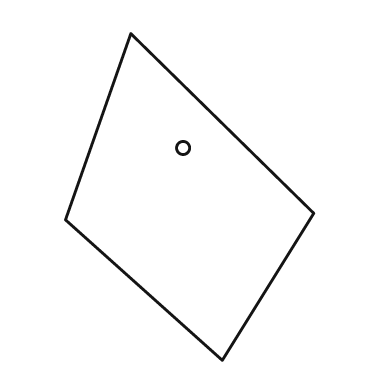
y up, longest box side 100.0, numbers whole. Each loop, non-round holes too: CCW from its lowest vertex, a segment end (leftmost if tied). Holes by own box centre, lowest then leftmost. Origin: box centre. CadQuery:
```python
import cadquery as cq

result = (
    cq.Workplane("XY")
    .moveTo(10.0, -50.0)
    .lineTo(38.0, -5.0)
    .lineTo(-18.0, 50.0)
    .lineTo(-38.0, -7.0)
    .close()
    .moveTo(-2.0, 15.0)
    .circle(2.0)
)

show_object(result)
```